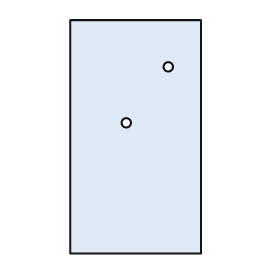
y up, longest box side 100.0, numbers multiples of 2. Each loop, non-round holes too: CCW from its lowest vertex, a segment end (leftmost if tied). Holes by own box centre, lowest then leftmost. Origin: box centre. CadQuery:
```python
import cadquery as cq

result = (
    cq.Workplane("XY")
    .moveTo(-28.0, -50.0)
    .lineTo(28.0, -50.0)
    .lineTo(28.0, 50.0)
    .lineTo(-28.0, 50.0)
    .close()
    .moveTo(-4.0, 6.0)
    .circle(2.0)
    .moveTo(14.0, 30.0)
    .circle(2.0)
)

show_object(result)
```